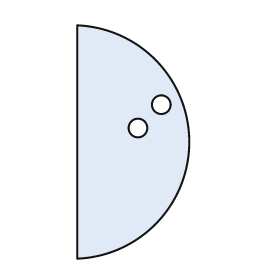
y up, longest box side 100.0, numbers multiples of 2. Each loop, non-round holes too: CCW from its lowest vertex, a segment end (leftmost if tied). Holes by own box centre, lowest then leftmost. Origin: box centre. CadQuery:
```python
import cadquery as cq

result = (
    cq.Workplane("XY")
    .moveTo(-24.0, -50.0)
    .threePointArc((24.0, 0.0), (-24.0, 50.0))
    .close()
    .moveTo(2.0, 6.0)
    .circle(4.0)
    .moveTo(12.0, 16.0)
    .circle(4.0)
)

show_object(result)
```